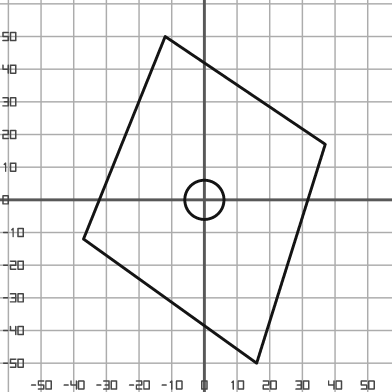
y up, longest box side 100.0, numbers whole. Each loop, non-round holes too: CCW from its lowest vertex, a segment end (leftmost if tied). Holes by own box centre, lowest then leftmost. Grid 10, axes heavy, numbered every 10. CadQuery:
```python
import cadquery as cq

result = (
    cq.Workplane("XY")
    .moveTo(16.0, -50.0)
    .lineTo(37.0, 17.0)
    .lineTo(-12.0, 50.0)
    .lineTo(-37.0, -12.0)
    .close()
    .moveTo(0.0, 0.0)
    .circle(6.0)
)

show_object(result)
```